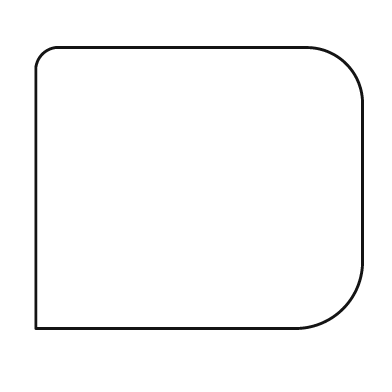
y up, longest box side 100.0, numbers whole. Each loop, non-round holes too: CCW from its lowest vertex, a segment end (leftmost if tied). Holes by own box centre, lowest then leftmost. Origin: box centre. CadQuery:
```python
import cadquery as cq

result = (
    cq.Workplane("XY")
    .moveTo(-50.0, -43.0)
    .lineTo(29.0, -43.0)
    .threePointArc((44.0, -37.0), (50.0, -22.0))
    .lineTo(50.0, 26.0)
    .threePointArc((45.0, 38.0), (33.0, 43.0))
    .lineTo(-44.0, 43.0)
    .threePointArc((-48.0, 41.0), (-50.0, 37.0))
    .close()
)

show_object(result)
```